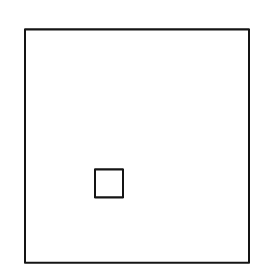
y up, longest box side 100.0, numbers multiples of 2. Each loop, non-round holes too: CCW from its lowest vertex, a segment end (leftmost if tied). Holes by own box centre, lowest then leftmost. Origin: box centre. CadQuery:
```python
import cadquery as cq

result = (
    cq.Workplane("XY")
    .moveTo(-48.0, -50.0)
    .lineTo(48.0, -50.0)
    .lineTo(48.0, 50.0)
    .lineTo(-48.0, 50.0)
    .close()
    .moveTo(-18.0, -22.0)
    .lineTo(-6.0, -22.0)
    .lineTo(-6.0, -10.0)
    .lineTo(-18.0, -10.0)
    .close()
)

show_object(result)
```